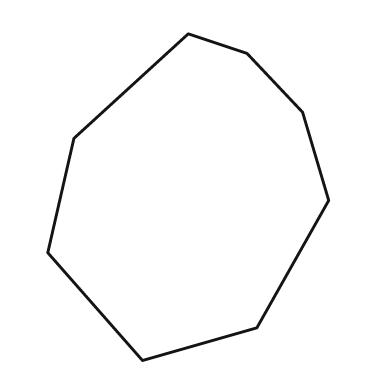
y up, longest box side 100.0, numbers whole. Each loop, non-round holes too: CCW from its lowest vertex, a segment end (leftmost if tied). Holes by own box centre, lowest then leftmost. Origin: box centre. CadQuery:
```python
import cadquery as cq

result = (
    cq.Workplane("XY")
    .moveTo(-14.0, -50.0)
    .lineTo(21.0, -40.0)
    .lineTo(43.0, -1.0)
    .lineTo(35.0, 26.0)
    .lineTo(18.0, 44.0)
    .lineTo(0.0, 50.0)
    .lineTo(-35.0, 18.0)
    .lineTo(-43.0, -17.0)
    .close()
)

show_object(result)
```